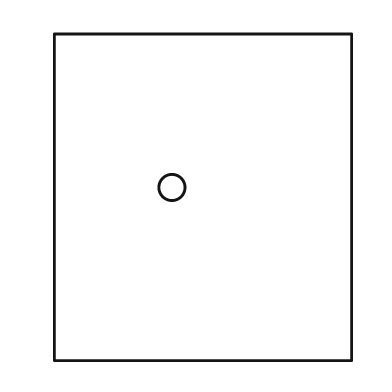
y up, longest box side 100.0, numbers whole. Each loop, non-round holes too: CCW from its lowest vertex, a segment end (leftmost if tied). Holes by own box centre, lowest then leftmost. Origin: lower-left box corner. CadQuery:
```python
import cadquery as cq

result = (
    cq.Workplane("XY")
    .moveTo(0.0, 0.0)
    .lineTo(91.0, 0.0)
    .lineTo(91.0, 100.0)
    .lineTo(0.0, 100.0)
    .close()
    .moveTo(36.0, 53.0)
    .circle(4.0)
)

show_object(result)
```